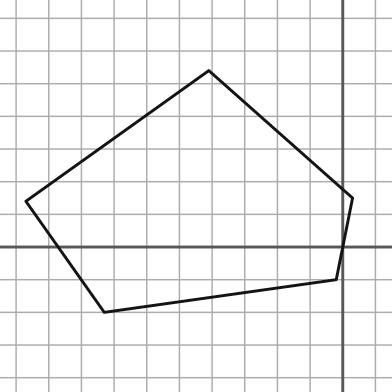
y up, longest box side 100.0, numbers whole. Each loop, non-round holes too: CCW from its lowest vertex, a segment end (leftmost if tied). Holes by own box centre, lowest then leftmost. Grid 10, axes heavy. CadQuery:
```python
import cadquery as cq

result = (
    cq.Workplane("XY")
    .moveTo(-73.0, -20.0)
    .lineTo(-2.0, -10.0)
    .lineTo(3.0, 15.0)
    .lineTo(-41.0, 54.0)
    .lineTo(-97.0, 14.0)
    .close()
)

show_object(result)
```